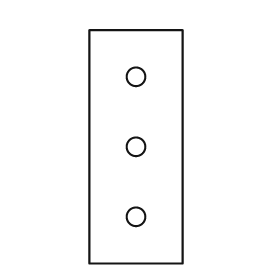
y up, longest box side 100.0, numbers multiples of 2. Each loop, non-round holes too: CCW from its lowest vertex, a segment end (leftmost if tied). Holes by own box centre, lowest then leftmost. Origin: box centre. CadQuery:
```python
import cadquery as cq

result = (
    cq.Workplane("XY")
    .moveTo(-20.0, -50.0)
    .lineTo(20.0, -50.0)
    .lineTo(20.0, 50.0)
    .lineTo(-20.0, 50.0)
    .close()
    .moveTo(0.0, -30.0)
    .circle(4.0)
    .moveTo(0.0, 0.0)
    .circle(4.0)
    .moveTo(0.0, 30.0)
    .circle(4.0)
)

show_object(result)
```